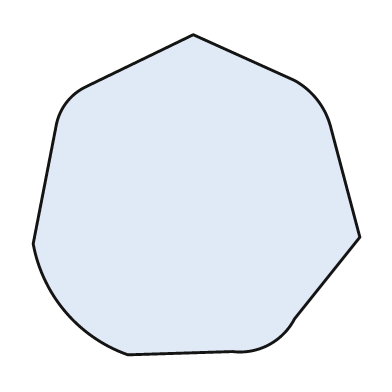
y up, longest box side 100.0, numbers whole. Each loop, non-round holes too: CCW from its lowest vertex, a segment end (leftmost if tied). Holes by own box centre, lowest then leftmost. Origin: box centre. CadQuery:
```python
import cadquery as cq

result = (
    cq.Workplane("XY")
    .moveTo(-21.0, -49.0)
    .lineTo(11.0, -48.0)
    .threePointArc((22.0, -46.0), (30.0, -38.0))
    .lineTo(50.0, -13.0)
    .lineTo(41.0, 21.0)
    .threePointArc((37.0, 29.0), (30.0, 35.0))
    .lineTo(-1.0, 49.0)
    .lineTo(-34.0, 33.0)
    .threePointArc((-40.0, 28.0), (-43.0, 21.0))
    .lineTo(-50.0, -15.0)
    .threePointArc((-40.0, -36.0), (-21.0, -49.0))
    .close()
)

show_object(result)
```